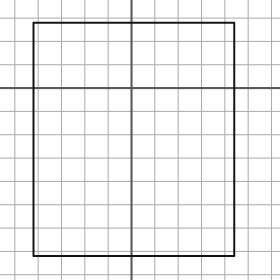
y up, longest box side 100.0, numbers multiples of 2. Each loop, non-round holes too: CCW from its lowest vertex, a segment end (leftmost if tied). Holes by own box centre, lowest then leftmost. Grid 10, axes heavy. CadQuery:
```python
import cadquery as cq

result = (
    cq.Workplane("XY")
    .moveTo(-42.0, -72.0)
    .lineTo(44.0, -72.0)
    .lineTo(44.0, 28.0)
    .lineTo(-42.0, 28.0)
    .close()
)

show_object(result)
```